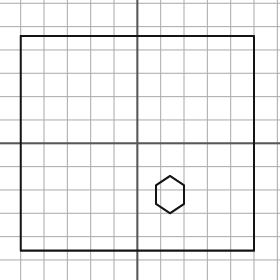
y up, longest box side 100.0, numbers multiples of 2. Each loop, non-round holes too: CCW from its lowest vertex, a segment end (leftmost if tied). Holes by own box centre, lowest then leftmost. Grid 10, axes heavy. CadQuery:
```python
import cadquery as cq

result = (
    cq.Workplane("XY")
    .moveTo(-50.0, -46.0)
    .lineTo(50.0, -46.0)
    .lineTo(50.0, 46.0)
    .lineTo(-50.0, 46.0)
    .close()
    .moveTo(14.0, -30.0)
    .lineTo(20.0, -26.0)
    .lineTo(20.0, -18.0)
    .lineTo(14.0, -14.0)
    .lineTo(8.0, -18.0)
    .lineTo(8.0, -26.0)
    .close()
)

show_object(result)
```